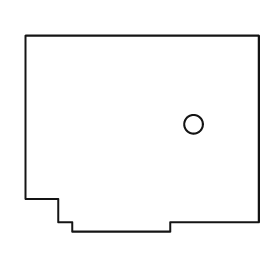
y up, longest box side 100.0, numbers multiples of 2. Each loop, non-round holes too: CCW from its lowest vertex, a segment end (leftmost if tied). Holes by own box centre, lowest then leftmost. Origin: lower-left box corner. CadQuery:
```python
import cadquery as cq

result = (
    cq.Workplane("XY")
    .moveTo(20.0, 0.0)
    .lineTo(62.0, 0.0)
    .lineTo(62.0, 4.0)
    .lineTo(100.0, 4.0)
    .lineTo(100.0, 84.0)
    .lineTo(0.0, 84.0)
    .lineTo(0.0, 14.0)
    .lineTo(14.0, 14.0)
    .lineTo(14.0, 4.0)
    .lineTo(20.0, 4.0)
    .close()
    .moveTo(72.0, 46.0)
    .circle(4.0)
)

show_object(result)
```